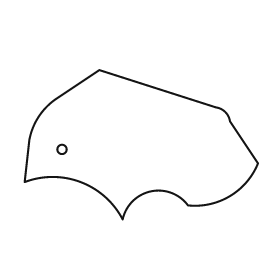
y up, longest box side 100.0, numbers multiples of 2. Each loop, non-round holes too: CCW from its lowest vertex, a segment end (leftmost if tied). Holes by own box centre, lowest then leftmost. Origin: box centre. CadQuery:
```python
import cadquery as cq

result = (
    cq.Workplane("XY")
    .moveTo(-8.0, -32.0)
    .threePointArc((4.0, -20.0), (20.0, -26.0))
    .threePointArc((38.0, -22.0), (50.0, -8.0))
    .lineTo(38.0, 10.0)
    .threePointArc((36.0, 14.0), (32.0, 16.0))
    .lineTo(-18.0, 32.0)
    .lineTo(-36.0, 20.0)
    .threePointArc((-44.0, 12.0), (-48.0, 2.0))
    .lineTo(-50.0, -16.0)
    .threePointArc((-26.0, -16.0), (-8.0, -32.0))
    .close()
    .moveTo(-34.0, -2.0)
    .circle(2.0)
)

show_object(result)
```